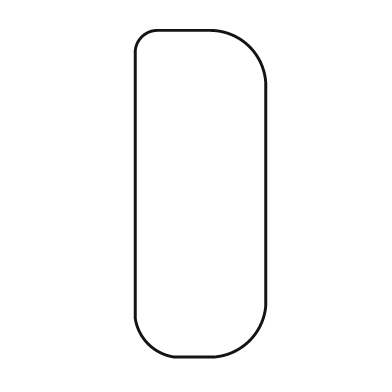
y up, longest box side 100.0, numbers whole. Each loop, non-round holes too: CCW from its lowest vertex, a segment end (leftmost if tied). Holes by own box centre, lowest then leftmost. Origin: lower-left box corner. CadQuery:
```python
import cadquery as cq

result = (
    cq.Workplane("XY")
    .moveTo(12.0, 0.0)
    .lineTo(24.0, 0.0)
    .threePointArc((35.0, 5.0), (40.0, 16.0))
    .lineTo(40.0, 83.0)
    .threePointArc((35.0, 95.0), (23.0, 100.0))
    .lineTo(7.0, 100.0)
    .threePointArc((2.0, 98.0), (0.0, 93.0))
    .lineTo(0.0, 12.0)
    .threePointArc((4.0, 4.0), (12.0, 0.0))
    .close()
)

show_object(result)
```